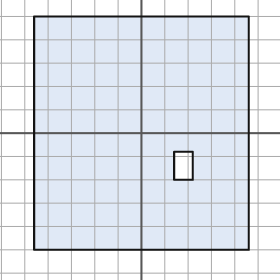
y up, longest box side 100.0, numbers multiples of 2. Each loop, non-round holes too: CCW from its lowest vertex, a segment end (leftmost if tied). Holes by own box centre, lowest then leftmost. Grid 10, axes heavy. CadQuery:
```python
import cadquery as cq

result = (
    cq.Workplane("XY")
    .moveTo(-46.0, -50.0)
    .lineTo(46.0, -50.0)
    .lineTo(46.0, 50.0)
    .lineTo(-46.0, 50.0)
    .close()
    .moveTo(14.0, -20.0)
    .lineTo(22.0, -20.0)
    .lineTo(22.0, -8.0)
    .lineTo(14.0, -8.0)
    .close()
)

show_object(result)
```